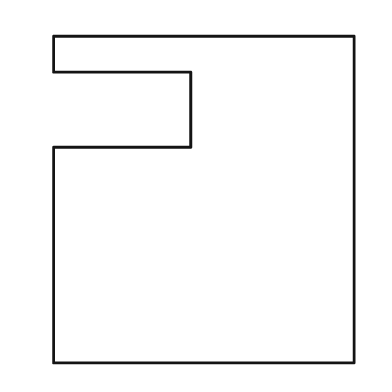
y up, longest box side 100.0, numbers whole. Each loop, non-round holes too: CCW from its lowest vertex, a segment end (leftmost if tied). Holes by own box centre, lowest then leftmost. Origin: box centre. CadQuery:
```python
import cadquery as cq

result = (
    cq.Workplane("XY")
    .moveTo(-46.0, -50.0)
    .lineTo(46.0, -50.0)
    .lineTo(46.0, 50.0)
    .lineTo(-46.0, 50.0)
    .lineTo(-46.0, 39.0)
    .lineTo(-4.0, 39.0)
    .lineTo(-4.0, 16.0)
    .lineTo(-46.0, 16.0)
    .close()
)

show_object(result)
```